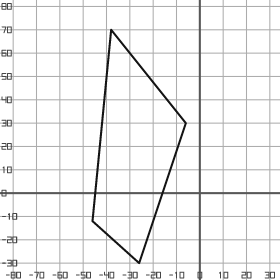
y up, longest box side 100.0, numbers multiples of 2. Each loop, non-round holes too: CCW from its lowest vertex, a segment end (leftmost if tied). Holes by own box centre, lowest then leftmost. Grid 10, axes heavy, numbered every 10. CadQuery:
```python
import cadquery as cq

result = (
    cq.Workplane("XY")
    .moveTo(-26.0, -30.0)
    .lineTo(-6.0, 30.0)
    .lineTo(-38.0, 70.0)
    .lineTo(-46.0, -12.0)
    .close()
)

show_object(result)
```